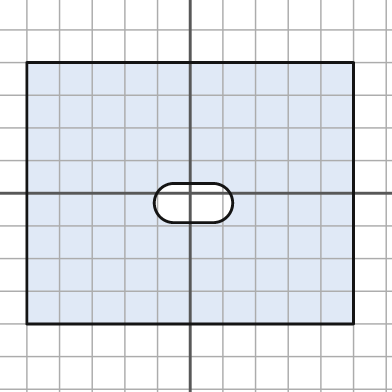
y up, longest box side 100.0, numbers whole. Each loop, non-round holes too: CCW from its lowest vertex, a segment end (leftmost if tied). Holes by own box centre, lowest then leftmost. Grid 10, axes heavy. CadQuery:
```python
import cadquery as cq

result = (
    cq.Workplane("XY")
    .moveTo(-50.0, -40.0)
    .lineTo(50.0, -40.0)
    .lineTo(50.0, 40.0)
    .lineTo(-50.0, 40.0)
    .close()
    .moveTo(-5.0, -9.0)
    .lineTo(7.0, -9.0)
    .threePointArc((13.0, -3.0), (7.0, 3.0))
    .lineTo(-5.0, 3.0)
    .threePointArc((-11.0, -3.0), (-5.0, -9.0))
    .close()
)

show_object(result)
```